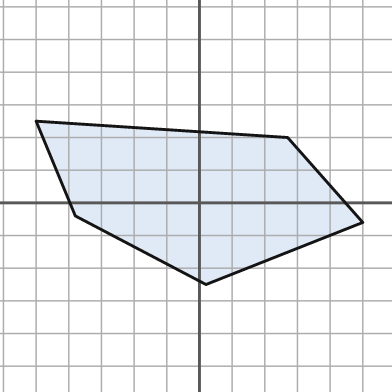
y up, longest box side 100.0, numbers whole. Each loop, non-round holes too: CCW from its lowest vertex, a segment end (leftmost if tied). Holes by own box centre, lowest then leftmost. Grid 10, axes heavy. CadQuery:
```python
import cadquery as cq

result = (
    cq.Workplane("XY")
    .moveTo(2.0, -25.0)
    .lineTo(50.0, -6.0)
    .lineTo(27.0, 20.0)
    .lineTo(-50.0, 25.0)
    .lineTo(-38.0, -4.0)
    .close()
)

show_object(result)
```